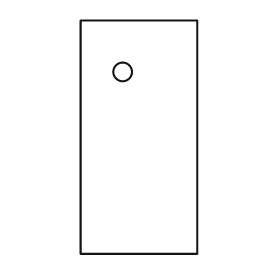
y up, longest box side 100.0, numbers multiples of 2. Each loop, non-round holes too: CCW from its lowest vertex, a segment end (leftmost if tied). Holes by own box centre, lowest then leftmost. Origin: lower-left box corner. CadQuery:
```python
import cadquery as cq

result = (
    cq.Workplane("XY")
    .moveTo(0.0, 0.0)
    .lineTo(50.0, 0.0)
    .lineTo(50.0, 100.0)
    .lineTo(0.0, 100.0)
    .close()
    .moveTo(18.0, 78.0)
    .circle(4.0)
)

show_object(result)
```